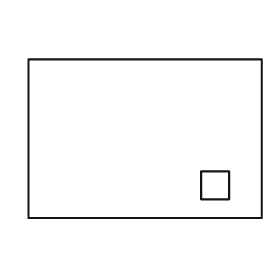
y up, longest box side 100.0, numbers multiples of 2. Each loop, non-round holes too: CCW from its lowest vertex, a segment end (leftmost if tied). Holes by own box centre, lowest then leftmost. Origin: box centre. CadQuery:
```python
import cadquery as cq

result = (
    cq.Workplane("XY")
    .moveTo(-50.0, -34.0)
    .lineTo(50.0, -34.0)
    .lineTo(50.0, 34.0)
    .lineTo(-50.0, 34.0)
    .close()
    .moveTo(24.0, -26.0)
    .lineTo(36.0, -26.0)
    .lineTo(36.0, -14.0)
    .lineTo(24.0, -14.0)
    .close()
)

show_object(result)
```